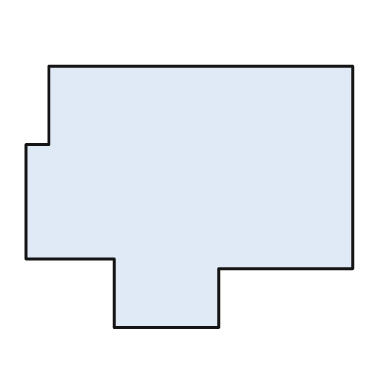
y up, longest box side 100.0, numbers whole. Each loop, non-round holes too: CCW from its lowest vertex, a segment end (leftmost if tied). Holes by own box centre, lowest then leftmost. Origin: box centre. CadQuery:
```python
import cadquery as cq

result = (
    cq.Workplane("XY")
    .moveTo(-23.0, -40.0)
    .lineTo(9.0, -40.0)
    .lineTo(9.0, -22.0)
    .lineTo(50.0, -22.0)
    .lineTo(50.0, 40.0)
    .lineTo(-43.0, 40.0)
    .lineTo(-43.0, 16.0)
    .lineTo(-50.0, 16.0)
    .lineTo(-50.0, -19.0)
    .lineTo(-23.0, -19.0)
    .close()
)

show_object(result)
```